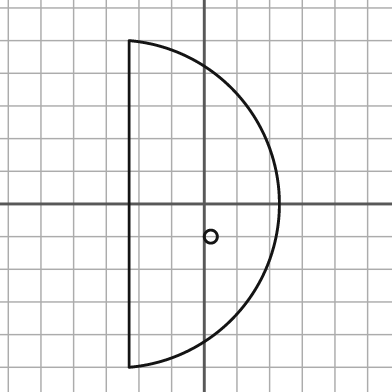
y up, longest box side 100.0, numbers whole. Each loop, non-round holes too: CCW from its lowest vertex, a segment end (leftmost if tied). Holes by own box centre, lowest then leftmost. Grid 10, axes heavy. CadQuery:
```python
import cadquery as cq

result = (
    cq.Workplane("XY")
    .moveTo(-23.0, -50.0)
    .threePointArc((23.0, 0.0), (-23.0, 50.0))
    .close()
    .moveTo(2.0, -10.0)
    .circle(2.0)
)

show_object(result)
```